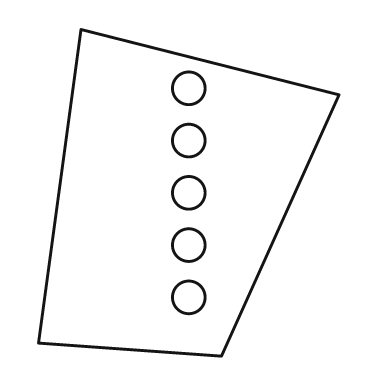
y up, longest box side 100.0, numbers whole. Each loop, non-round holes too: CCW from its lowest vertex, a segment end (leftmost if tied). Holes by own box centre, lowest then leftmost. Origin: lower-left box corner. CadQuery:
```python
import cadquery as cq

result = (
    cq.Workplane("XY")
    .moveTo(56.0, 0.0)
    .lineTo(92.0, 80.0)
    .lineTo(13.0, 100.0)
    .lineTo(0.0, 4.0)
    .close()
    .moveTo(46.0, 18.0)
    .circle(5.0)
    .moveTo(46.0, 34.0)
    .circle(5.0)
    .moveTo(46.0, 50.0)
    .circle(5.0)
    .moveTo(46.0, 66.0)
    .circle(5.0)
    .moveTo(46.0, 82.0)
    .circle(5.0)
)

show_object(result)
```